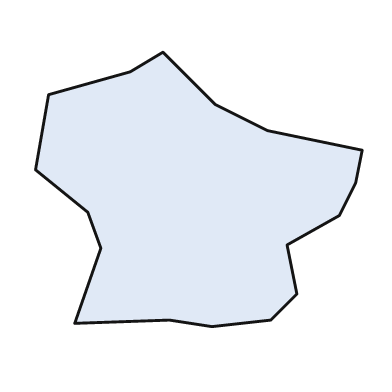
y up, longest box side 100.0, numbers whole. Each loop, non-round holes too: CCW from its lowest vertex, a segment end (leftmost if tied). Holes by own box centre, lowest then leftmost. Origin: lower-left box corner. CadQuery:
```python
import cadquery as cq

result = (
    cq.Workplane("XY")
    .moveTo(54.0, 0.0)
    .lineTo(72.0, 2.0)
    .lineTo(80.0, 10.0)
    .lineTo(77.0, 25.0)
    .lineTo(93.0, 34.0)
    .lineTo(98.0, 44.0)
    .lineTo(100.0, 54.0)
    .lineTo(71.0, 60.0)
    .lineTo(55.0, 68.0)
    .lineTo(39.0, 84.0)
    .lineTo(29.0, 78.0)
    .lineTo(4.0, 71.0)
    .lineTo(0.0, 48.0)
    .lineTo(16.0, 35.0)
    .lineTo(20.0, 24.0)
    .lineTo(12.0, 1.0)
    .lineTo(41.0, 2.0)
    .close()
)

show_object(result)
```